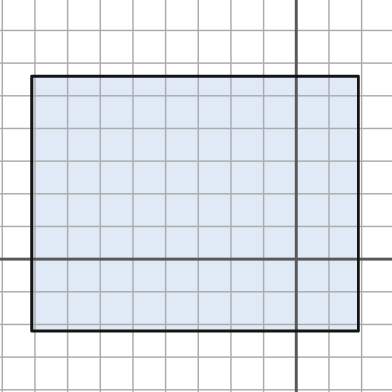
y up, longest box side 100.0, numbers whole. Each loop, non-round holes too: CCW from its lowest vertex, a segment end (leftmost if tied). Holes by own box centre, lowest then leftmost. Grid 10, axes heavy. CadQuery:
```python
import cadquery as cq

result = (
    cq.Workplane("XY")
    .moveTo(-81.0, -22.0)
    .lineTo(19.0, -22.0)
    .lineTo(19.0, 56.0)
    .lineTo(-81.0, 56.0)
    .close()
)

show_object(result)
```